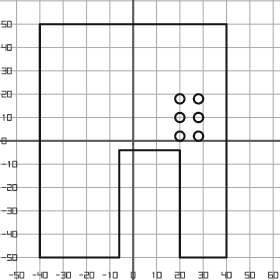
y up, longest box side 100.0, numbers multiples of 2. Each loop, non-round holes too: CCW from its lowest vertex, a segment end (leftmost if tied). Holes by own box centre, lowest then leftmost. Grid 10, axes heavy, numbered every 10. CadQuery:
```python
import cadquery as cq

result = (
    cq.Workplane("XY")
    .moveTo(-40.0, -50.0)
    .lineTo(-6.0, -50.0)
    .lineTo(-6.0, -4.0)
    .lineTo(20.0, -4.0)
    .lineTo(20.0, -50.0)
    .lineTo(40.0, -50.0)
    .lineTo(40.0, 50.0)
    .lineTo(-40.0, 50.0)
    .close()
    .moveTo(20.0, 2.0)
    .circle(2.0)
    .moveTo(28.0, 2.0)
    .circle(2.0)
    .moveTo(20.0, 10.0)
    .circle(2.0)
    .moveTo(28.0, 10.0)
    .circle(2.0)
    .moveTo(20.0, 18.0)
    .circle(2.0)
    .moveTo(28.0, 18.0)
    .circle(2.0)
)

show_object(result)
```